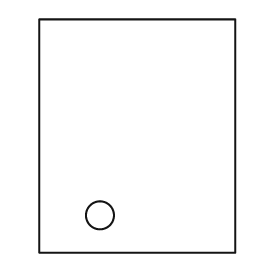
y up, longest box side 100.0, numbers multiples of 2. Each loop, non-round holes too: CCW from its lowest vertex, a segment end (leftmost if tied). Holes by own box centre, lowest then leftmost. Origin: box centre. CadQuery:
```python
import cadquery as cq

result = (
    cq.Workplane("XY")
    .moveTo(-42.0, -50.0)
    .lineTo(42.0, -50.0)
    .lineTo(42.0, 50.0)
    .lineTo(-42.0, 50.0)
    .close()
    .moveTo(-16.0, -34.0)
    .circle(6.0)
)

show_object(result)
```